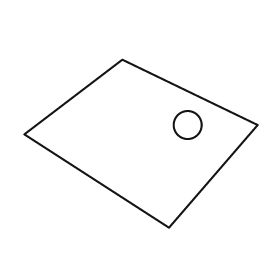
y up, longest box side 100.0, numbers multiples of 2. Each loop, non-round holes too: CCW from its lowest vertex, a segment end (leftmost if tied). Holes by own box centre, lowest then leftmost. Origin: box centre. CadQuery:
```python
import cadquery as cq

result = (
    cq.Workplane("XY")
    .moveTo(12.0, -36.0)
    .lineTo(50.0, 8.0)
    .lineTo(-8.0, 36.0)
    .lineTo(-50.0, 4.0)
    .close()
    .moveTo(20.0, 8.0)
    .circle(6.0)
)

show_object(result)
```